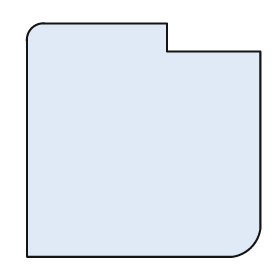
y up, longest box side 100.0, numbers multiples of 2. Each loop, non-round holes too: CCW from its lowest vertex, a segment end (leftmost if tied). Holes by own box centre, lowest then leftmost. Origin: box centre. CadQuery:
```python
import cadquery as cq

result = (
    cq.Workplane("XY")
    .moveTo(-50.0, -50.0)
    .lineTo(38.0, -50.0)
    .threePointArc((46.0, -46.0), (50.0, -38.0))
    .lineTo(50.0, 38.0)
    .lineTo(10.0, 38.0)
    .lineTo(10.0, 50.0)
    .lineTo(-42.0, 50.0)
    .threePointArc((-48.0, 48.0), (-50.0, 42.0))
    .close()
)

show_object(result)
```